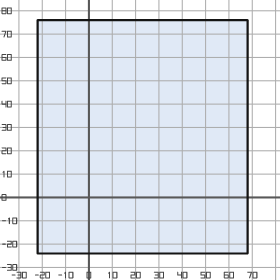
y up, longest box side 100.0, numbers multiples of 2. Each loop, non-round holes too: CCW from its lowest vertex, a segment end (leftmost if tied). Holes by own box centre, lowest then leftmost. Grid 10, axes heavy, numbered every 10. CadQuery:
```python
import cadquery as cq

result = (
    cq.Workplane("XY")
    .moveTo(-22.0, -24.0)
    .lineTo(68.0, -24.0)
    .lineTo(68.0, 76.0)
    .lineTo(-22.0, 76.0)
    .close()
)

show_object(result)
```